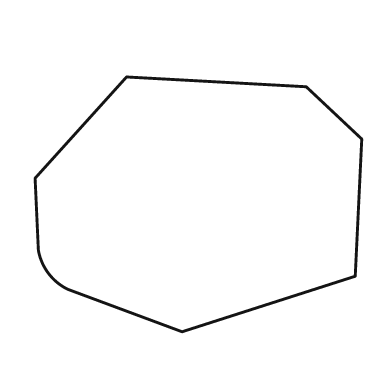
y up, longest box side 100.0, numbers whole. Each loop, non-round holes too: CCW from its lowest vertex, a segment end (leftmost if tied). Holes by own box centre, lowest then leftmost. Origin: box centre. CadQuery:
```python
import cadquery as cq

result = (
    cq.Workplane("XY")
    .moveTo(-5.0, -39.0)
    .lineTo(48.0, -22.0)
    .lineTo(50.0, 20.0)
    .lineTo(33.0, 36.0)
    .lineTo(-22.0, 39.0)
    .lineTo(-50.0, 8.0)
    .lineTo(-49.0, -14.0)
    .threePointArc((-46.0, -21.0), (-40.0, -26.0))
    .close()
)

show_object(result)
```